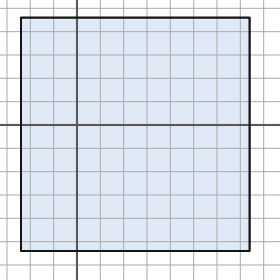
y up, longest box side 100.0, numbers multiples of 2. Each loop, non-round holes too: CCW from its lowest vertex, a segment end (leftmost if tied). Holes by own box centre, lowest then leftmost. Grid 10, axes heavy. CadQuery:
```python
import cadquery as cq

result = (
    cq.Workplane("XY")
    .moveTo(-24.0, -54.0)
    .lineTo(74.0, -54.0)
    .lineTo(74.0, 46.0)
    .lineTo(-24.0, 46.0)
    .close()
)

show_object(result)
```